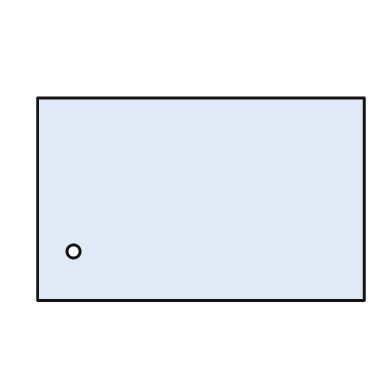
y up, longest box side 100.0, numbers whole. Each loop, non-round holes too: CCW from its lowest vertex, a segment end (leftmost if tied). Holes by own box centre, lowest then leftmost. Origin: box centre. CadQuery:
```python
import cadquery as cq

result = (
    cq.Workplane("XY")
    .moveTo(-50.0, -31.0)
    .lineTo(50.0, -31.0)
    .lineTo(50.0, 31.0)
    .lineTo(-50.0, 31.0)
    .close()
    .moveTo(-39.0, -16.0)
    .circle(2.0)
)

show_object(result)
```